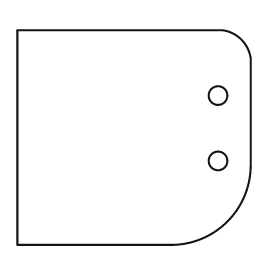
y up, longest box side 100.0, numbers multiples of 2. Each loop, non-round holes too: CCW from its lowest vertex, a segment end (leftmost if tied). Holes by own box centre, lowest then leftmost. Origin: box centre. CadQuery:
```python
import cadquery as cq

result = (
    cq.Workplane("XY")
    .moveTo(-50.0, -46.0)
    .lineTo(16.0, -46.0)
    .threePointArc((40.0, -36.0), (50.0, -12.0))
    .lineTo(50.0, 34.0)
    .threePointArc((46.0, 42.0), (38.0, 46.0))
    .lineTo(-50.0, 46.0)
    .close()
    .moveTo(36.0, -10.0)
    .circle(4.0)
    .moveTo(36.0, 18.0)
    .circle(4.0)
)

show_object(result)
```